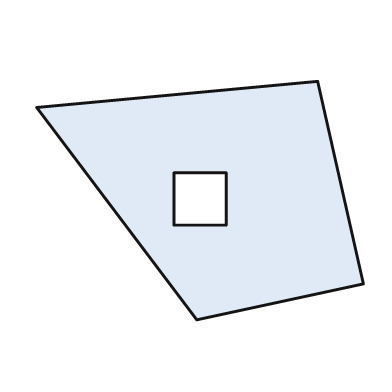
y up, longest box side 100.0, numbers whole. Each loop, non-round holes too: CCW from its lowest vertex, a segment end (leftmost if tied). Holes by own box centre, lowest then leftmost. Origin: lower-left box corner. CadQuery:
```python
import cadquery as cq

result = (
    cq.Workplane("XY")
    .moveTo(49.0, 0.0)
    .lineTo(100.0, 11.0)
    .lineTo(86.0, 73.0)
    .lineTo(0.0, 65.0)
    .close()
    .moveTo(42.0, 29.0)
    .lineTo(58.0, 29.0)
    .lineTo(58.0, 45.0)
    .lineTo(42.0, 45.0)
    .close()
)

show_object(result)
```